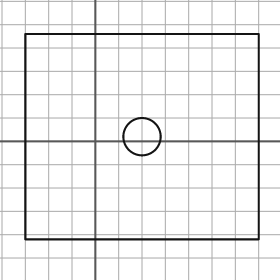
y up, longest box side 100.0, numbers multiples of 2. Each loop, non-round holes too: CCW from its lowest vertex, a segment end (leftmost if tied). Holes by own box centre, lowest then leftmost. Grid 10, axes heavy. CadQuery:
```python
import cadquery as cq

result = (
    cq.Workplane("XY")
    .moveTo(-30.0, -42.0)
    .lineTo(70.0, -42.0)
    .lineTo(70.0, 46.0)
    .lineTo(-30.0, 46.0)
    .close()
    .moveTo(20.0, 2.0)
    .circle(8.0)
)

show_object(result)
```